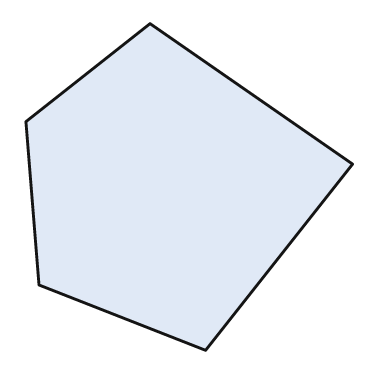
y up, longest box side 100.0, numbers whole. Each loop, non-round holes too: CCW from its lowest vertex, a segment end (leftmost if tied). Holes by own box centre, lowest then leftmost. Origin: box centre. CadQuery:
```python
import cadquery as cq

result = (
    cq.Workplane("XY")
    .moveTo(5.0, -50.0)
    .lineTo(50.0, 7.0)
    .lineTo(-12.0, 50.0)
    .lineTo(-50.0, 20.0)
    .lineTo(-46.0, -30.0)
    .close()
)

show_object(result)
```